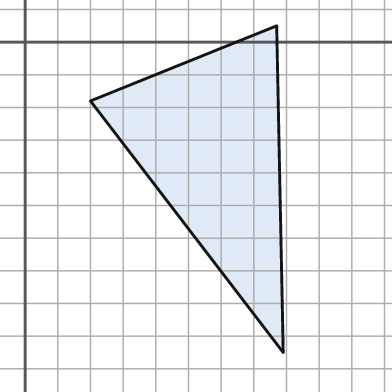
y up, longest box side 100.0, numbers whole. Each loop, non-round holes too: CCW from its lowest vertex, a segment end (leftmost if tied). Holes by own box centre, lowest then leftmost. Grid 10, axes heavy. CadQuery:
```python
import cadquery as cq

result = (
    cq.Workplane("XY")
    .moveTo(79.0, -95.0)
    .lineTo(77.0, 5.0)
    .lineTo(20.0, -18.0)
    .close()
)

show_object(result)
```